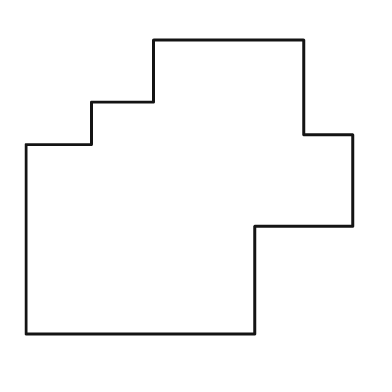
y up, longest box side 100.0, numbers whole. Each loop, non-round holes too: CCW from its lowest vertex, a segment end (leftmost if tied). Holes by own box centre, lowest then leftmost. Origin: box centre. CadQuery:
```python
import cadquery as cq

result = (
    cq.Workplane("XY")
    .moveTo(-50.0, -45.0)
    .lineTo(20.0, -45.0)
    .lineTo(20.0, -12.0)
    .lineTo(50.0, -12.0)
    .lineTo(50.0, 16.0)
    .lineTo(35.0, 16.0)
    .lineTo(35.0, 45.0)
    .lineTo(-11.0, 45.0)
    .lineTo(-11.0, 26.0)
    .lineTo(-30.0, 26.0)
    .lineTo(-30.0, 13.0)
    .lineTo(-50.0, 13.0)
    .close()
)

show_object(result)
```